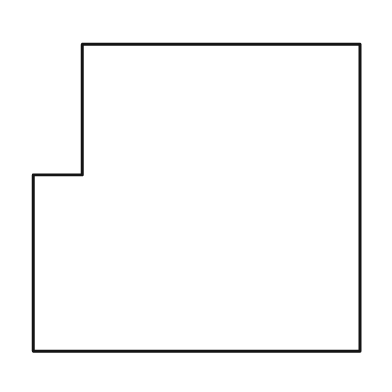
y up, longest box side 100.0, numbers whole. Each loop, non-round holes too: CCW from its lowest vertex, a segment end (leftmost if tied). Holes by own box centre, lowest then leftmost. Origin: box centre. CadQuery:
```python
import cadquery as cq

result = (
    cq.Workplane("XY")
    .moveTo(-50.0, -47.0)
    .lineTo(50.0, -47.0)
    .lineTo(50.0, 47.0)
    .lineTo(-35.0, 47.0)
    .lineTo(-35.0, 7.0)
    .lineTo(-50.0, 7.0)
    .close()
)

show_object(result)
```